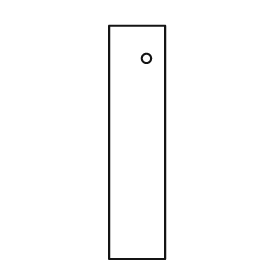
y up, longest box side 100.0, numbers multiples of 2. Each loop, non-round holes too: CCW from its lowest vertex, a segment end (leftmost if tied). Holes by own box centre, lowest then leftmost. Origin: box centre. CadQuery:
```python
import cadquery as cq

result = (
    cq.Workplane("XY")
    .moveTo(-12.0, -50.0)
    .lineTo(12.0, -50.0)
    .lineTo(12.0, 50.0)
    .lineTo(-12.0, 50.0)
    .close()
    .moveTo(4.0, 36.0)
    .circle(2.0)
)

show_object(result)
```